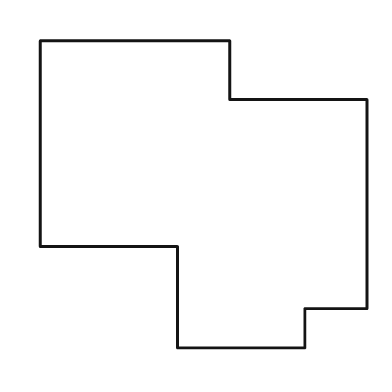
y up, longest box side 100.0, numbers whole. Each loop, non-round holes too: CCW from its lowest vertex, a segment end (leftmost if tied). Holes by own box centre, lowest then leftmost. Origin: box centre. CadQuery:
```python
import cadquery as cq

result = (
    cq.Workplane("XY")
    .moveTo(-8.0, -47.0)
    .lineTo(31.0, -47.0)
    .lineTo(31.0, -35.0)
    .lineTo(50.0, -35.0)
    .lineTo(50.0, 29.0)
    .lineTo(8.0, 29.0)
    .lineTo(8.0, 47.0)
    .lineTo(-50.0, 47.0)
    .lineTo(-50.0, -16.0)
    .lineTo(-8.0, -16.0)
    .close()
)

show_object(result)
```